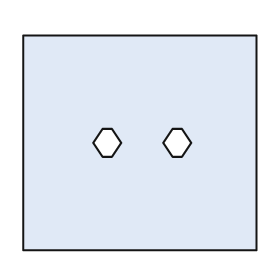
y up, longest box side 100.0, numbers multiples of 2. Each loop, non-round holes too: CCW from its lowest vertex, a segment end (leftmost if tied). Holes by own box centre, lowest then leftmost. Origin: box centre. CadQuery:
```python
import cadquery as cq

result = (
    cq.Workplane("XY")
    .moveTo(-50.0, -46.0)
    .lineTo(50.0, -46.0)
    .lineTo(50.0, 46.0)
    .lineTo(-50.0, 46.0)
    .close()
    .moveTo(-16.0, -6.0)
    .lineTo(-12.0, -6.0)
    .lineTo(-8.0, 0.0)
    .lineTo(-12.0, 6.0)
    .lineTo(-16.0, 6.0)
    .lineTo(-20.0, 0.0)
    .close()
    .moveTo(14.0, -6.0)
    .lineTo(18.0, -6.0)
    .lineTo(22.0, 0.0)
    .lineTo(18.0, 6.0)
    .lineTo(14.0, 6.0)
    .lineTo(10.0, 0.0)
    .close()
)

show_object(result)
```